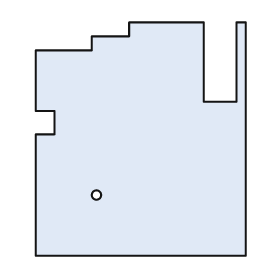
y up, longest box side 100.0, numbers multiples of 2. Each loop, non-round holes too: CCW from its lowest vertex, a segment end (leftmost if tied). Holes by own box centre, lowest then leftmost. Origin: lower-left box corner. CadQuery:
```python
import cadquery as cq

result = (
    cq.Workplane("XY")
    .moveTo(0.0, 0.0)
    .lineTo(90.0, 0.0)
    .lineTo(90.0, 100.0)
    .lineTo(86.0, 100.0)
    .lineTo(86.0, 66.0)
    .lineTo(72.0, 66.0)
    .lineTo(72.0, 100.0)
    .lineTo(40.0, 100.0)
    .lineTo(40.0, 94.0)
    .lineTo(24.0, 94.0)
    .lineTo(24.0, 88.0)
    .lineTo(0.0, 88.0)
    .lineTo(0.0, 62.0)
    .lineTo(8.0, 62.0)
    .lineTo(8.0, 52.0)
    .lineTo(0.0, 52.0)
    .close()
    .moveTo(26.0, 26.0)
    .circle(2.0)
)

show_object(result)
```